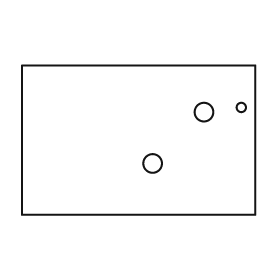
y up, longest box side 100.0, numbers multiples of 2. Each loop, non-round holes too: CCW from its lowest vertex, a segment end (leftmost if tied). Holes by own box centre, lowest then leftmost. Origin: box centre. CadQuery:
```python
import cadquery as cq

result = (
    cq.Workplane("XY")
    .moveTo(-50.0, -32.0)
    .lineTo(50.0, -32.0)
    .lineTo(50.0, 32.0)
    .lineTo(-50.0, 32.0)
    .close()
    .moveTo(6.0, -10.0)
    .circle(4.0)
    .moveTo(28.0, 12.0)
    .circle(4.0)
    .moveTo(44.0, 14.0)
    .circle(2.0)
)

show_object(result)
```